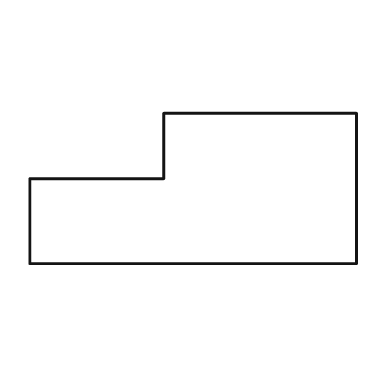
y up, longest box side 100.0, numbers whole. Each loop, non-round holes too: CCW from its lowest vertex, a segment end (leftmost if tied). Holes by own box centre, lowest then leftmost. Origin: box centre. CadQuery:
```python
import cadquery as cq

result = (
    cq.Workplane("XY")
    .moveTo(-50.0, -23.0)
    .lineTo(50.0, -23.0)
    .lineTo(50.0, 23.0)
    .lineTo(-9.0, 23.0)
    .lineTo(-9.0, 3.0)
    .lineTo(-50.0, 3.0)
    .close()
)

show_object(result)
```